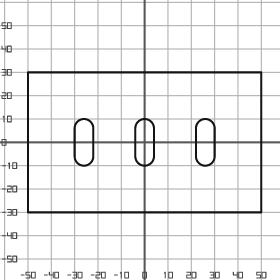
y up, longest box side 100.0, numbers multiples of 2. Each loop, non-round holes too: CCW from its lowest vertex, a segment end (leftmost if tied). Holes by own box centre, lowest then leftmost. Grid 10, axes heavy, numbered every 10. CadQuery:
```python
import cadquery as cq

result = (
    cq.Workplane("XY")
    .moveTo(-50.0, -30.0)
    .lineTo(50.0, -30.0)
    .lineTo(50.0, 30.0)
    .lineTo(-50.0, 30.0)
    .close()
    .moveTo(-30.0, -6.0)
    .threePointArc((-26.0, -10.0), (-22.0, -6.0))
    .lineTo(-22.0, 6.0)
    .threePointArc((-26.0, 10.0), (-30.0, 6.0))
    .close()
    .moveTo(-4.0, -6.0)
    .threePointArc((0.0, -10.0), (4.0, -6.0))
    .lineTo(4.0, 6.0)
    .threePointArc((0.0, 10.0), (-4.0, 6.0))
    .close()
    .moveTo(22.0, -6.0)
    .threePointArc((26.0, -10.0), (30.0, -6.0))
    .lineTo(30.0, 6.0)
    .threePointArc((26.0, 10.0), (22.0, 6.0))
    .close()
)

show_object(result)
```